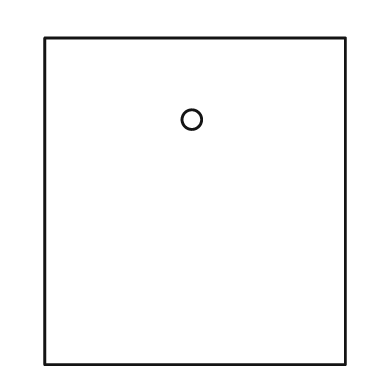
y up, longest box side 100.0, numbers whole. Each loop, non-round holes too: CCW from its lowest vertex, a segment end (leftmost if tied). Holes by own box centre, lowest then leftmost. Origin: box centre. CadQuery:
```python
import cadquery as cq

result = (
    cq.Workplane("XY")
    .moveTo(-46.0, -50.0)
    .lineTo(46.0, -50.0)
    .lineTo(46.0, 50.0)
    .lineTo(-46.0, 50.0)
    .close()
    .moveTo(-1.0, 25.0)
    .circle(3.0)
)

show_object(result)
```